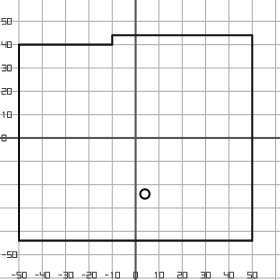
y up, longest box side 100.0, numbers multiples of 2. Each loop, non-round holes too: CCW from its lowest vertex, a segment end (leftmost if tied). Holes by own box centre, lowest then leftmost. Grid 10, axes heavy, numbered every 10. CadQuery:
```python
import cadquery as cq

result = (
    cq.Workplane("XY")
    .moveTo(-50.0, -44.0)
    .lineTo(50.0, -44.0)
    .lineTo(50.0, 44.0)
    .lineTo(-10.0, 44.0)
    .lineTo(-10.0, 40.0)
    .lineTo(-50.0, 40.0)
    .close()
    .moveTo(4.0, -24.0)
    .circle(2.0)
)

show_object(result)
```